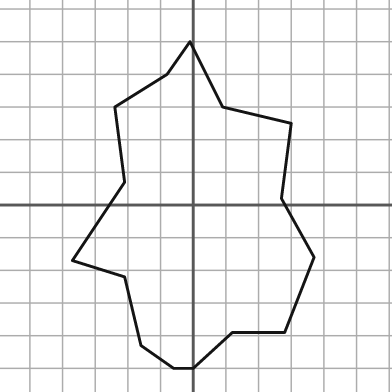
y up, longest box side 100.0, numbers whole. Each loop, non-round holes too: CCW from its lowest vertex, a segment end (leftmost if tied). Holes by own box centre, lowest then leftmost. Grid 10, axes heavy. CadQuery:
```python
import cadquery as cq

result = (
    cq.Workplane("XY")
    .moveTo(-6.0, -50.0)
    .lineTo(0.0, -50.0)
    .lineTo(12.0, -39.0)
    .lineTo(28.0, -39.0)
    .lineTo(37.0, -16.0)
    .lineTo(27.0, 2.0)
    .lineTo(30.0, 25.0)
    .lineTo(9.0, 30.0)
    .lineTo(-1.0, 50.0)
    .lineTo(-8.0, 40.0)
    .lineTo(-24.0, 30.0)
    .lineTo(-21.0, 7.0)
    .lineTo(-37.0, -17.0)
    .lineTo(-21.0, -22.0)
    .lineTo(-16.0, -43.0)
    .close()
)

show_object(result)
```